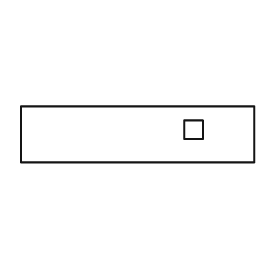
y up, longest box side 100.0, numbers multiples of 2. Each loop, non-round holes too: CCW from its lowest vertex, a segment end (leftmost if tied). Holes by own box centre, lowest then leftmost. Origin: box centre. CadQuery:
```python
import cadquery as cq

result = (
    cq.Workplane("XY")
    .moveTo(-50.0, -12.0)
    .lineTo(50.0, -12.0)
    .lineTo(50.0, 12.0)
    .lineTo(-50.0, 12.0)
    .close()
    .moveTo(20.0, -2.0)
    .lineTo(28.0, -2.0)
    .lineTo(28.0, 6.0)
    .lineTo(20.0, 6.0)
    .close()
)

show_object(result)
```